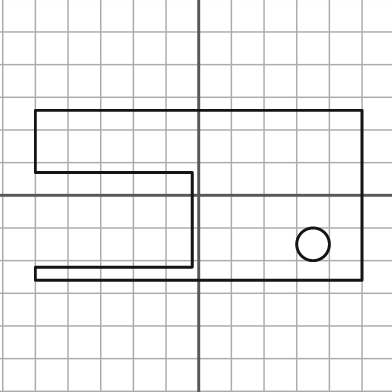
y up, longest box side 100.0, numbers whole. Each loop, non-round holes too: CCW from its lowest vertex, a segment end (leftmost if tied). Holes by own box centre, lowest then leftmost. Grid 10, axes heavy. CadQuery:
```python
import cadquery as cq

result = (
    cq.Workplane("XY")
    .moveTo(-50.0, -26.0)
    .lineTo(50.0, -26.0)
    .lineTo(50.0, 26.0)
    .lineTo(-50.0, 26.0)
    .lineTo(-50.0, 7.0)
    .lineTo(-2.0, 7.0)
    .lineTo(-2.0, -22.0)
    .lineTo(-50.0, -22.0)
    .close()
    .moveTo(35.0, -15.0)
    .circle(5.0)
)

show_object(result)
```